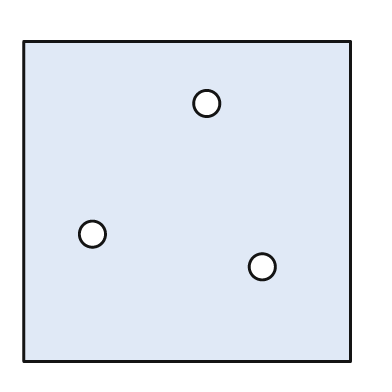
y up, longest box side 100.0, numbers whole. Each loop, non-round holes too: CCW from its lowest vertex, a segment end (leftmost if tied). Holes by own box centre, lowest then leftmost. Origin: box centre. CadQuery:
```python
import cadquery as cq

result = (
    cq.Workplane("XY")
    .moveTo(-50.0, -49.0)
    .lineTo(50.0, -49.0)
    .lineTo(50.0, 49.0)
    .lineTo(-50.0, 49.0)
    .close()
    .moveTo(23.0, -20.0)
    .circle(4.0)
    .moveTo(-29.0, -10.0)
    .circle(4.0)
    .moveTo(6.0, 30.0)
    .circle(4.0)
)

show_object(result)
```